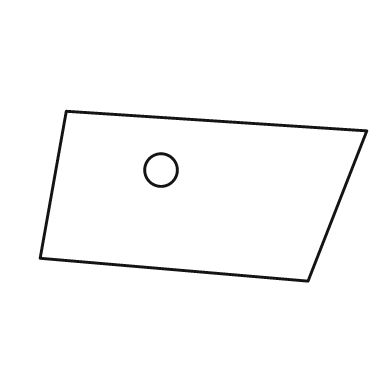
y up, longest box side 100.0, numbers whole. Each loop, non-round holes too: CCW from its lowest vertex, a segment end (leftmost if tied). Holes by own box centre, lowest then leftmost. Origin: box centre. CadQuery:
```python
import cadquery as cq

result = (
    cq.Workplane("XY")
    .moveTo(32.0, -26.0)
    .lineTo(50.0, 20.0)
    .lineTo(-42.0, 26.0)
    .lineTo(-50.0, -19.0)
    .close()
    .moveTo(-13.0, 8.0)
    .circle(5.0)
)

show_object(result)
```